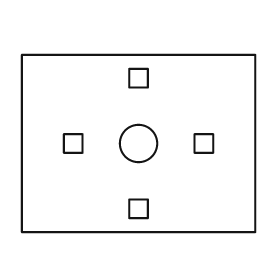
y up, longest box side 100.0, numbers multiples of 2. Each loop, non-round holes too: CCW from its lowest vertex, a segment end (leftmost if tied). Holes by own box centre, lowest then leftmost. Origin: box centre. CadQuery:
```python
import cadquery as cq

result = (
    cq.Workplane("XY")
    .moveTo(-50.0, -38.0)
    .lineTo(50.0, -38.0)
    .lineTo(50.0, 38.0)
    .lineTo(-50.0, 38.0)
    .close()
    .moveTo(-4.0, -32.0)
    .lineTo(4.0, -32.0)
    .lineTo(4.0, -24.0)
    .lineTo(-4.0, -24.0)
    .close()
    .moveTo(-32.0, -4.0)
    .lineTo(-24.0, -4.0)
    .lineTo(-24.0, 4.0)
    .lineTo(-32.0, 4.0)
    .close()
    .moveTo(0.0, 0.0)
    .circle(8.0)
    .moveTo(24.0, -4.0)
    .lineTo(32.0, -4.0)
    .lineTo(32.0, 4.0)
    .lineTo(24.0, 4.0)
    .close()
    .moveTo(-4.0, 24.0)
    .lineTo(4.0, 24.0)
    .lineTo(4.0, 32.0)
    .lineTo(-4.0, 32.0)
    .close()
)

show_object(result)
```